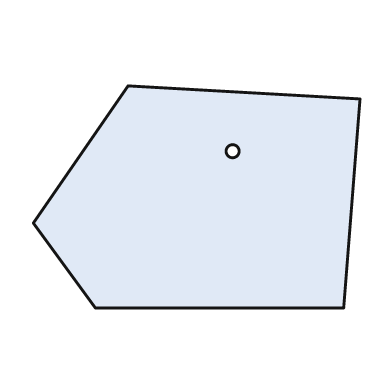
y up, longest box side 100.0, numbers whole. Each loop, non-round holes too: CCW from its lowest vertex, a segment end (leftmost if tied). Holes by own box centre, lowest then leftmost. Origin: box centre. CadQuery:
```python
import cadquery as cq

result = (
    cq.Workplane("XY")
    .moveTo(-31.0, -34.0)
    .lineTo(45.0, -34.0)
    .lineTo(50.0, 30.0)
    .lineTo(-21.0, 34.0)
    .lineTo(-50.0, -8.0)
    .close()
    .moveTo(11.0, 14.0)
    .circle(2.0)
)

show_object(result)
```